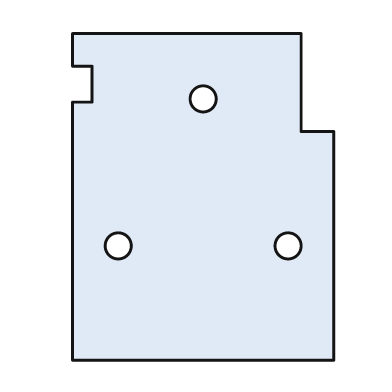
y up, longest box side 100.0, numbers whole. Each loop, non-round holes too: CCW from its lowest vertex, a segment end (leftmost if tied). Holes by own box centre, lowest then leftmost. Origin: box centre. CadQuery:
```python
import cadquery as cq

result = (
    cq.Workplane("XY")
    .moveTo(-40.0, -50.0)
    .lineTo(40.0, -50.0)
    .lineTo(40.0, 20.0)
    .lineTo(30.0, 20.0)
    .lineTo(30.0, 50.0)
    .lineTo(-40.0, 50.0)
    .lineTo(-40.0, 40.0)
    .lineTo(-34.0, 40.0)
    .lineTo(-34.0, 29.0)
    .lineTo(-40.0, 29.0)
    .close()
    .moveTo(-26.0, -15.0)
    .circle(4.0)
    .moveTo(26.0, -15.0)
    .circle(4.0)
    .moveTo(0.0, 30.0)
    .circle(4.0)
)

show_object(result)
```